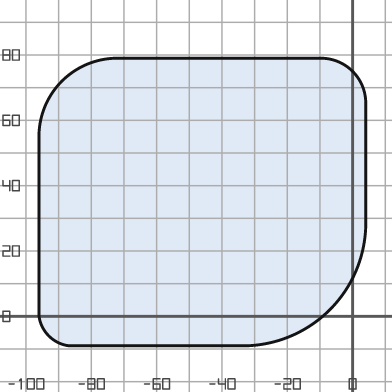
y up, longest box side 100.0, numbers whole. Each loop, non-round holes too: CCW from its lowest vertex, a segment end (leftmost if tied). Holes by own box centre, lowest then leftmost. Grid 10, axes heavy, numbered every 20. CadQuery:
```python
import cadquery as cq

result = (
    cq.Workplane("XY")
    .moveTo(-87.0, -9.0)
    .lineTo(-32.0, -9.0)
    .threePointArc((-7.0, 2.0), (4.0, 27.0))
    .lineTo(4.0, 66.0)
    .threePointArc((0.0, 75.0), (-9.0, 79.0))
    .lineTo(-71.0, 79.0)
    .threePointArc((-89.0, 72.0), (-96.0, 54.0))
    .lineTo(-96.0, 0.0)
    .threePointArc((-93.0, -6.0), (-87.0, -9.0))
    .close()
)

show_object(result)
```